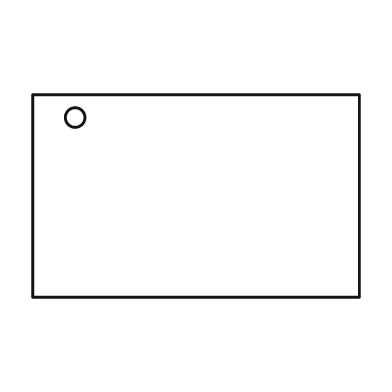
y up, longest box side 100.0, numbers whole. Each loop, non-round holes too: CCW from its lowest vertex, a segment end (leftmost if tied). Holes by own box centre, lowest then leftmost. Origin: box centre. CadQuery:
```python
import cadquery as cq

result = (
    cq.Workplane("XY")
    .moveTo(-50.0, -31.0)
    .lineTo(50.0, -31.0)
    .lineTo(50.0, 31.0)
    .lineTo(-50.0, 31.0)
    .close()
    .moveTo(-37.0, 24.0)
    .circle(3.0)
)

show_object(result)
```